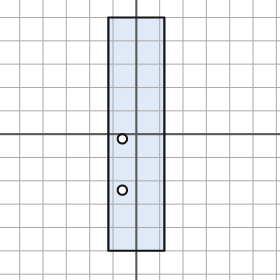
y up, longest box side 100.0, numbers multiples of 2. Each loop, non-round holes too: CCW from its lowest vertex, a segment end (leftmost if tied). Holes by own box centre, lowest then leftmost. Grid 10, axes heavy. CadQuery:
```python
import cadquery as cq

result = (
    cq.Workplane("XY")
    .moveTo(-12.0, -50.0)
    .lineTo(12.0, -50.0)
    .lineTo(12.0, 50.0)
    .lineTo(-12.0, 50.0)
    .close()
    .moveTo(-6.0, -24.0)
    .circle(2.0)
    .moveTo(-6.0, -2.0)
    .circle(2.0)
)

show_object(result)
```